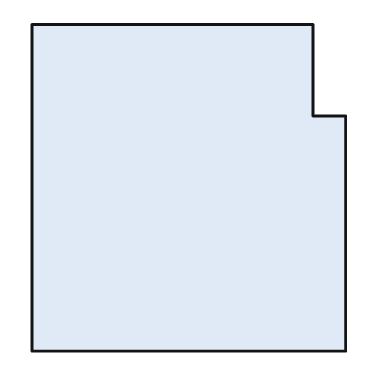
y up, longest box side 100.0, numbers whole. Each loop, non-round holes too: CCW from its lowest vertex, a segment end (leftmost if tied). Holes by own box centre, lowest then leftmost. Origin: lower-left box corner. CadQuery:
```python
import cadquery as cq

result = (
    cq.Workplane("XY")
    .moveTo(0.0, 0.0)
    .lineTo(96.0, 0.0)
    .lineTo(96.0, 72.0)
    .lineTo(86.0, 72.0)
    .lineTo(86.0, 100.0)
    .lineTo(0.0, 100.0)
    .close()
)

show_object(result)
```